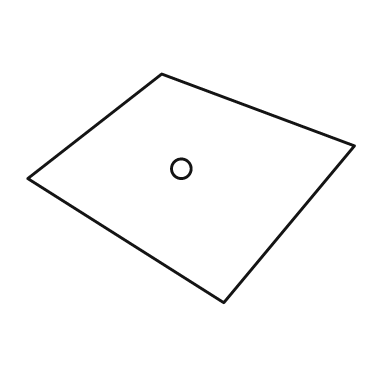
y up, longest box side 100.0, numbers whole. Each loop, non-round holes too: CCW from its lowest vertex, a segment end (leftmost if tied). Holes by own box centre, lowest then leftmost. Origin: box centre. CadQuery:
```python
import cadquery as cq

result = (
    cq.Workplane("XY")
    .moveTo(10.0, -35.0)
    .lineTo(50.0, 13.0)
    .lineTo(-9.0, 35.0)
    .lineTo(-50.0, 3.0)
    .close()
    .moveTo(-3.0, 6.0)
    .circle(3.0)
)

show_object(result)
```